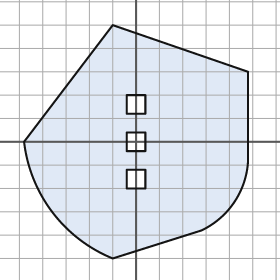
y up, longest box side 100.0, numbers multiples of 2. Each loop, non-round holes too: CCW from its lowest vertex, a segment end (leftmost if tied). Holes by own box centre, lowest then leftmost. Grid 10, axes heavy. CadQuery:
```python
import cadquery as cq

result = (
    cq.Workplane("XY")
    .moveTo(-10.0, -50.0)
    .lineTo(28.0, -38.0)
    .threePointArc((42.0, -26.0), (48.0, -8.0))
    .lineTo(48.0, 30.0)
    .lineTo(-10.0, 50.0)
    .lineTo(-48.0, 0.0)
    .threePointArc((-36.0, -30.0), (-10.0, -50.0))
    .close()
    .moveTo(-4.0, -20.0)
    .lineTo(4.0, -20.0)
    .lineTo(4.0, -12.0)
    .lineTo(-4.0, -12.0)
    .close()
    .moveTo(-4.0, -4.0)
    .lineTo(4.0, -4.0)
    .lineTo(4.0, 4.0)
    .lineTo(-4.0, 4.0)
    .close()
    .moveTo(-4.0, 12.0)
    .lineTo(4.0, 12.0)
    .lineTo(4.0, 20.0)
    .lineTo(-4.0, 20.0)
    .close()
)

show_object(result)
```